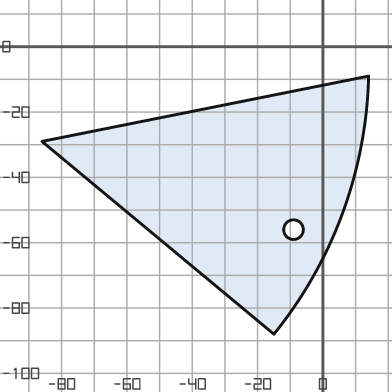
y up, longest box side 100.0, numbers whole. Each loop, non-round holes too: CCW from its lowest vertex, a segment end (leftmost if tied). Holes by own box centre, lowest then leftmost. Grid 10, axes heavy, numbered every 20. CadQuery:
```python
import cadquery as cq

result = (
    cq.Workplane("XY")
    .moveTo(-15.0, -88.0)
    .threePointArc((6.0, -51.0), (14.0, -9.0))
    .lineTo(-86.0, -29.0)
    .close()
    .moveTo(-9.0, -56.0)
    .circle(3.0)
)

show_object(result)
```